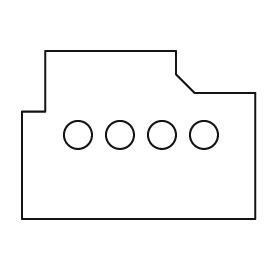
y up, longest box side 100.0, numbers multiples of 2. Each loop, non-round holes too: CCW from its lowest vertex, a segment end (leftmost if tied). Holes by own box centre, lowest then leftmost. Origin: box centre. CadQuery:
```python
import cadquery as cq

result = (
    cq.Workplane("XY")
    .moveTo(-50.0, -36.0)
    .lineTo(50.0, -36.0)
    .lineTo(50.0, 18.0)
    .lineTo(24.0, 18.0)
    .lineTo(16.0, 26.0)
    .lineTo(16.0, 36.0)
    .lineTo(-40.0, 36.0)
    .lineTo(-40.0, 10.0)
    .lineTo(-50.0, 10.0)
    .close()
    .moveTo(-26.0, 0.0)
    .circle(6.0)
    .moveTo(-8.0, 0.0)
    .circle(6.0)
    .moveTo(10.0, 0.0)
    .circle(6.0)
    .moveTo(28.0, 0.0)
    .circle(6.0)
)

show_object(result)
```